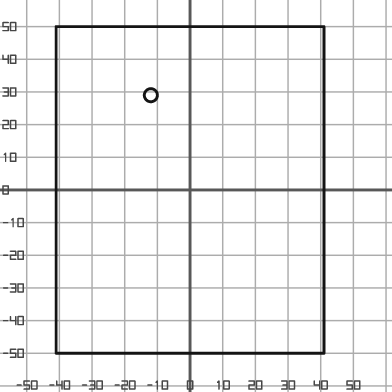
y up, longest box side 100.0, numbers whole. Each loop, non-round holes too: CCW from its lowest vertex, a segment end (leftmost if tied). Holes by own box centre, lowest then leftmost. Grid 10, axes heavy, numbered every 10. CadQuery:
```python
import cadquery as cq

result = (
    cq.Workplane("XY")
    .moveTo(-41.0, -50.0)
    .lineTo(41.0, -50.0)
    .lineTo(41.0, 50.0)
    .lineTo(-41.0, 50.0)
    .close()
    .moveTo(-12.0, 29.0)
    .circle(2.0)
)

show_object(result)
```